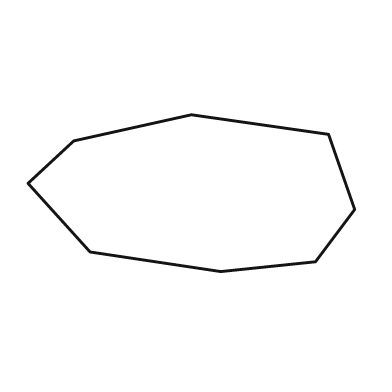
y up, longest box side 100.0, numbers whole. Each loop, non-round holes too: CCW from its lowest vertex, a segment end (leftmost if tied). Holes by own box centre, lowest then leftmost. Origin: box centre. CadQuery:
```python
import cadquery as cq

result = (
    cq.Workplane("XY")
    .moveTo(9.0, -24.0)
    .lineTo(38.0, -21.0)
    .lineTo(50.0, -5.0)
    .lineTo(42.0, 18.0)
    .lineTo(0.0, 24.0)
    .lineTo(-36.0, 16.0)
    .lineTo(-50.0, 3.0)
    .lineTo(-31.0, -18.0)
    .close()
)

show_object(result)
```